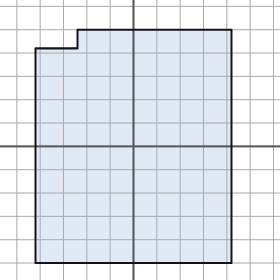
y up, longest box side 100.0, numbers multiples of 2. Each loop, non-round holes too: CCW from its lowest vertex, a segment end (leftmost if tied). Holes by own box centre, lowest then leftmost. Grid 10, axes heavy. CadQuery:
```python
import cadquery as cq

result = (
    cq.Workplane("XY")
    .moveTo(-42.0, -50.0)
    .lineTo(42.0, -50.0)
    .lineTo(42.0, 50.0)
    .lineTo(-24.0, 50.0)
    .lineTo(-24.0, 42.0)
    .lineTo(-42.0, 42.0)
    .close()
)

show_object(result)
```